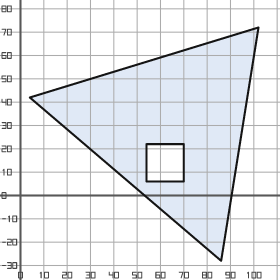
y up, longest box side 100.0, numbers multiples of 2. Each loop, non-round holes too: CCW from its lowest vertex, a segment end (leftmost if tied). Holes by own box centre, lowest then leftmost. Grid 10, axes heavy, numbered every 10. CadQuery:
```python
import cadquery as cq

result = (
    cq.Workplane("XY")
    .moveTo(86.0, -28.0)
    .lineTo(102.0, 72.0)
    .lineTo(4.0, 42.0)
    .close()
    .moveTo(54.0, 6.0)
    .lineTo(70.0, 6.0)
    .lineTo(70.0, 22.0)
    .lineTo(54.0, 22.0)
    .close()
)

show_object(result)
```